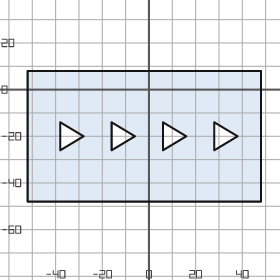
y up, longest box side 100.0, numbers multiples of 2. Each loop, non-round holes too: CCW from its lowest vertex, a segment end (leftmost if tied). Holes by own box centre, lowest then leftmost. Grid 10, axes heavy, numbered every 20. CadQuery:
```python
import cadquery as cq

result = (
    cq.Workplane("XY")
    .moveTo(-52.0, -48.0)
    .lineTo(48.0, -48.0)
    .lineTo(48.0, 8.0)
    .lineTo(-52.0, 8.0)
    .close()
    .moveTo(-38.0, -26.0)
    .lineTo(-28.0, -20.0)
    .lineTo(-38.0, -14.0)
    .close()
    .moveTo(-16.0, -26.0)
    .lineTo(-6.0, -20.0)
    .lineTo(-16.0, -14.0)
    .close()
    .moveTo(6.0, -26.0)
    .lineTo(16.0, -20.0)
    .lineTo(6.0, -14.0)
    .close()
    .moveTo(28.0, -26.0)
    .lineTo(38.0, -20.0)
    .lineTo(28.0, -14.0)
    .close()
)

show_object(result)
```